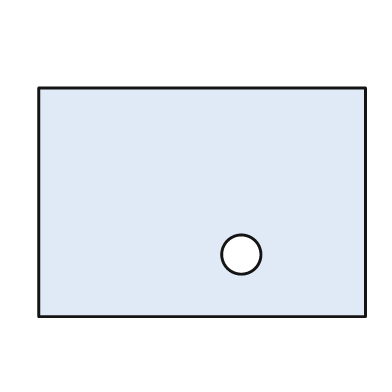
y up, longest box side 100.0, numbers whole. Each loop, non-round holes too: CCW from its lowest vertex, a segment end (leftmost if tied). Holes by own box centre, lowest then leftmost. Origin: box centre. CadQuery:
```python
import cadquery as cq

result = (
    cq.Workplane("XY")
    .moveTo(-50.0, -35.0)
    .lineTo(50.0, -35.0)
    .lineTo(50.0, 35.0)
    .lineTo(-50.0, 35.0)
    .close()
    .moveTo(12.0, -16.0)
    .circle(6.0)
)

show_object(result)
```